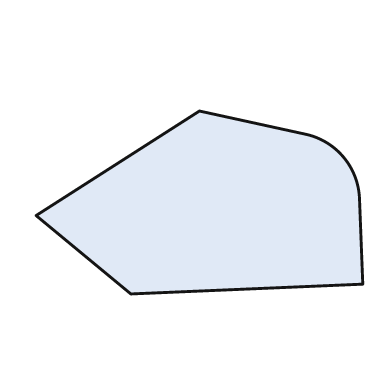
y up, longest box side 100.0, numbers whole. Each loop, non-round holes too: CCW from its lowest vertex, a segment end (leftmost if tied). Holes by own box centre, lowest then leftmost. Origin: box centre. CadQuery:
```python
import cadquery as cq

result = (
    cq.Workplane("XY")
    .moveTo(-21.0, -28.0)
    .lineTo(50.0, -25.0)
    .lineTo(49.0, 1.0)
    .threePointArc((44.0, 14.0), (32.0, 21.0))
    .lineTo(0.0, 28.0)
    .lineTo(-50.0, -4.0)
    .close()
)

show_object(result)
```